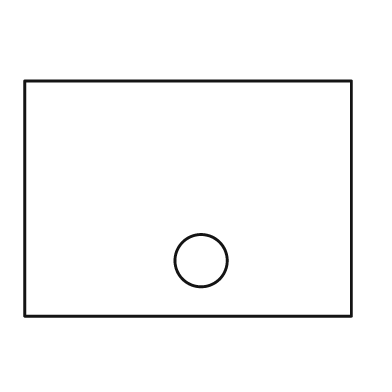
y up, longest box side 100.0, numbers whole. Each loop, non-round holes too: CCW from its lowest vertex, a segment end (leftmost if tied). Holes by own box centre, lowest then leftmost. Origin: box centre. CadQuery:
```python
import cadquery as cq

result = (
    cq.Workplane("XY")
    .moveTo(-50.0, -36.0)
    .lineTo(50.0, -36.0)
    .lineTo(50.0, 36.0)
    .lineTo(-50.0, 36.0)
    .close()
    .moveTo(4.0, -19.0)
    .circle(8.0)
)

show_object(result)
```